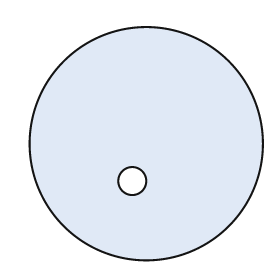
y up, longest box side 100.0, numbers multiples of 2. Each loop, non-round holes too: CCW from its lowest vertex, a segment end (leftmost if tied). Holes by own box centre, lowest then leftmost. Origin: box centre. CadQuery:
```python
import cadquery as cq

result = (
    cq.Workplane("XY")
    .moveTo(0.0, 0.0)
    .circle(50.0)
    .moveTo(-6.0, -16.0)
    .circle(6.0)
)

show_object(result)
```